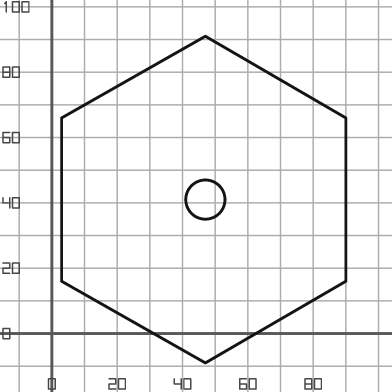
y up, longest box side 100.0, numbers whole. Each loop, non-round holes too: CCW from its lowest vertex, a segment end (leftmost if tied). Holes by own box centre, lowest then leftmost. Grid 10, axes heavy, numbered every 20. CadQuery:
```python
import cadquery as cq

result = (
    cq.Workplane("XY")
    .moveTo(47.0, -9.0)
    .lineTo(90.0, 16.0)
    .lineTo(90.0, 66.0)
    .lineTo(47.0, 91.0)
    .lineTo(3.0, 66.0)
    .lineTo(3.0, 16.0)
    .close()
    .moveTo(47.0, 41.0)
    .circle(6.0)
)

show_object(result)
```